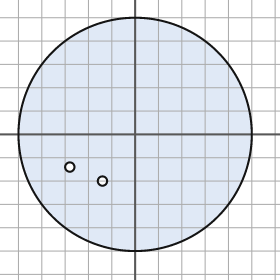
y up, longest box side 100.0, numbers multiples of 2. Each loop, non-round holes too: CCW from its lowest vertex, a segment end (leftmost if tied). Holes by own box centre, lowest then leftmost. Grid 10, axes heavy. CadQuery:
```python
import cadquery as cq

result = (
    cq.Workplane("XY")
    .moveTo(0.0, 0.0)
    .circle(50.0)
    .moveTo(-14.0, -20.0)
    .circle(2.0)
    .moveTo(-28.0, -14.0)
    .circle(2.0)
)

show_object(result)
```